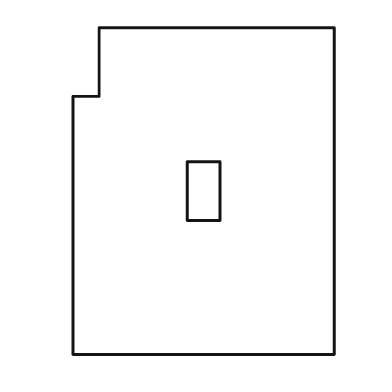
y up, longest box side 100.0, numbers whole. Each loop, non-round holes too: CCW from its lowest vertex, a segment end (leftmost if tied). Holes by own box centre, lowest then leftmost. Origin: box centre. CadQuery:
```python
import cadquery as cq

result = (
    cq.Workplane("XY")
    .moveTo(-40.0, -50.0)
    .lineTo(40.0, -50.0)
    .lineTo(40.0, 50.0)
    .lineTo(-32.0, 50.0)
    .lineTo(-32.0, 29.0)
    .lineTo(-40.0, 29.0)
    .close()
    .moveTo(-5.0, -9.0)
    .lineTo(5.0, -9.0)
    .lineTo(5.0, 9.0)
    .lineTo(-5.0, 9.0)
    .close()
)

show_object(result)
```